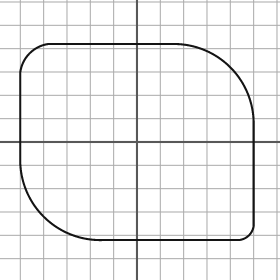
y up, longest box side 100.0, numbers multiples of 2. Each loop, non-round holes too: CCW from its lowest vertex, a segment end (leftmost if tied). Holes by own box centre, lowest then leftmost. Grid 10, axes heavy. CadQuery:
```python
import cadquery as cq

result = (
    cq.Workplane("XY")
    .moveTo(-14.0, -42.0)
    .lineTo(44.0, -42.0)
    .threePointArc((48.0, -40.0), (50.0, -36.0))
    .lineTo(50.0, 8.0)
    .threePointArc((40.0, 32.0), (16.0, 42.0))
    .lineTo(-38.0, 42.0)
    .threePointArc((-46.0, 38.0), (-50.0, 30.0))
    .lineTo(-50.0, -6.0)
    .threePointArc((-40.0, -32.0), (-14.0, -42.0))
    .close()
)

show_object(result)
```